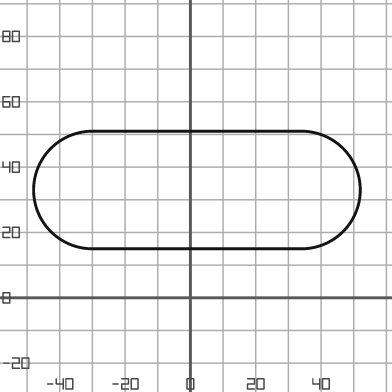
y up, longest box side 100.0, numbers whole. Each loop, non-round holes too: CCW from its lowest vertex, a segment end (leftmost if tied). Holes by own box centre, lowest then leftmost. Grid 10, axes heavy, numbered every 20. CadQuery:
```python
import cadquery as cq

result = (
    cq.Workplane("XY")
    .moveTo(-30.0, 15.0)
    .lineTo(34.0, 15.0)
    .threePointArc((52.0, 33.0), (34.0, 51.0))
    .lineTo(-30.0, 51.0)
    .threePointArc((-48.0, 33.0), (-30.0, 15.0))
    .close()
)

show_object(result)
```